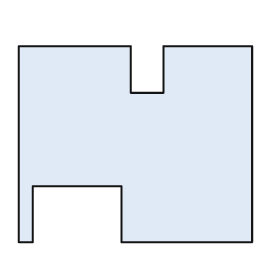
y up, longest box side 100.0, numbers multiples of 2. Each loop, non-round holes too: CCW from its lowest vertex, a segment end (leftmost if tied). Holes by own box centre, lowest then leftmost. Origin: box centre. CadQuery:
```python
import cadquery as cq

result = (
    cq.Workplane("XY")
    .moveTo(-50.0, -42.0)
    .lineTo(-44.0, -42.0)
    .lineTo(-44.0, -18.0)
    .lineTo(-6.0, -18.0)
    .lineTo(-6.0, -42.0)
    .lineTo(50.0, -42.0)
    .lineTo(50.0, 42.0)
    .lineTo(12.0, 42.0)
    .lineTo(12.0, 22.0)
    .lineTo(-2.0, 22.0)
    .lineTo(-2.0, 42.0)
    .lineTo(-50.0, 42.0)
    .close()
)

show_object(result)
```